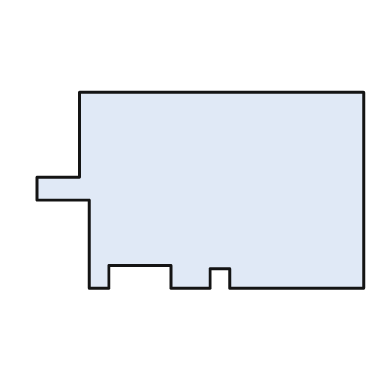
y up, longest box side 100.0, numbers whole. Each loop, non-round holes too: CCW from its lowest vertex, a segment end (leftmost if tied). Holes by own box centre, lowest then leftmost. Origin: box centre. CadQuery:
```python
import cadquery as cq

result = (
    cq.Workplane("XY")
    .moveTo(-34.0, -30.0)
    .lineTo(-28.0, -30.0)
    .lineTo(-28.0, -23.0)
    .lineTo(-9.0, -23.0)
    .lineTo(-9.0, -30.0)
    .lineTo(3.0, -30.0)
    .lineTo(3.0, -24.0)
    .lineTo(9.0, -24.0)
    .lineTo(9.0, -30.0)
    .lineTo(50.0, -30.0)
    .lineTo(50.0, 30.0)
    .lineTo(-37.0, 30.0)
    .lineTo(-37.0, 4.0)
    .lineTo(-50.0, 4.0)
    .lineTo(-50.0, -3.0)
    .lineTo(-34.0, -3.0)
    .close()
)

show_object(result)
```